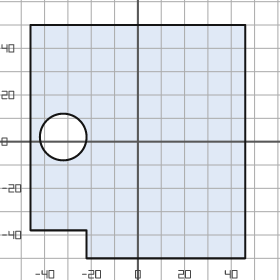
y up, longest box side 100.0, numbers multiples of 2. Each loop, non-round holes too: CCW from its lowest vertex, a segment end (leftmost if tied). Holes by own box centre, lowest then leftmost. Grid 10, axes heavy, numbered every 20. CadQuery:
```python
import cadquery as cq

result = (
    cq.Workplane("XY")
    .moveTo(-22.0, -50.0)
    .lineTo(46.0, -50.0)
    .lineTo(46.0, 50.0)
    .lineTo(-46.0, 50.0)
    .lineTo(-46.0, -38.0)
    .lineTo(-22.0, -38.0)
    .close()
    .moveTo(-32.0, 2.0)
    .circle(10.0)
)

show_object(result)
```